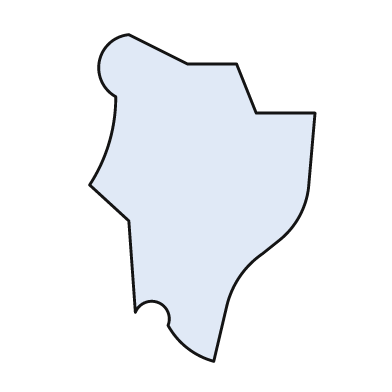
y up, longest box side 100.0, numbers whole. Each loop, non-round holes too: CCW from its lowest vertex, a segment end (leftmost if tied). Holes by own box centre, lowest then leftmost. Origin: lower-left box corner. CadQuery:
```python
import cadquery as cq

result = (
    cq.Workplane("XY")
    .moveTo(38.0, 0.0)
    .lineTo(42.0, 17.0)
    .threePointArc((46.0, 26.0), (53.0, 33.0))
    .lineTo(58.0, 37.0)
    .threePointArc((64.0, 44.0), (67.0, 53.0))
    .lineTo(69.0, 76.0)
    .lineTo(51.0, 76.0)
    .lineTo(45.0, 91.0)
    .lineTo(30.0, 91.0)
    .lineTo(12.0, 100.0)
    .threePointArc((3.0, 92.0), (8.0, 81.0))
    .threePointArc((6.0, 67.0), (0.0, 54.0))
    .lineTo(12.0, 43.0)
    .lineTo(14.0, 15.0)
    .threePointArc((21.0, 18.0), (24.0, 11.0))
    .threePointArc((30.0, 4.0), (38.0, 0.0))
    .close()
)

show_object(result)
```